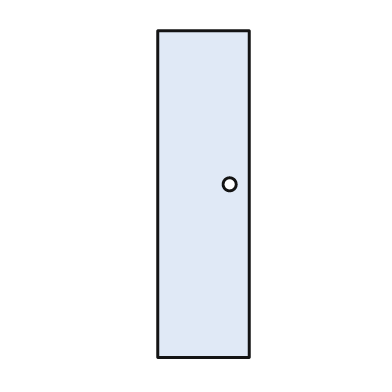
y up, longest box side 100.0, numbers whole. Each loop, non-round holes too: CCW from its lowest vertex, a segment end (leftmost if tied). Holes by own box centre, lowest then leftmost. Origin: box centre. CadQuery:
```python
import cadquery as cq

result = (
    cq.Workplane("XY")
    .moveTo(-14.0, -50.0)
    .lineTo(14.0, -50.0)
    .lineTo(14.0, 50.0)
    .lineTo(-14.0, 50.0)
    .close()
    .moveTo(8.0, 3.0)
    .circle(2.0)
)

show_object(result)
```